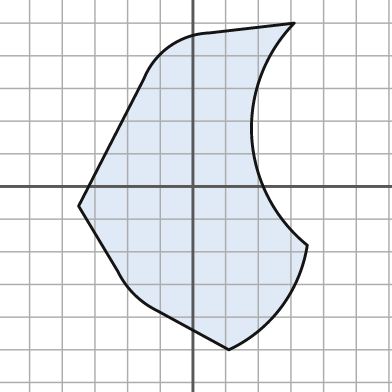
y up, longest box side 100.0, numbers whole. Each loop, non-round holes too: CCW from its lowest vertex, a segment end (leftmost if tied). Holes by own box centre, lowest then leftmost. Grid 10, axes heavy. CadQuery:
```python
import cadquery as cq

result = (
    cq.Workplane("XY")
    .moveTo(11.0, -50.0)
    .threePointArc((27.0, -37.0), (35.0, -18.0))
    .threePointArc((18.0, 15.0), (31.0, 50.0))
    .lineTo(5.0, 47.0)
    .threePointArc((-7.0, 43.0), (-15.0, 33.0))
    .lineTo(-35.0, -6.0)
    .lineTo(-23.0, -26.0)
    .threePointArc((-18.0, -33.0), (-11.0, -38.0))
    .close()
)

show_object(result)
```